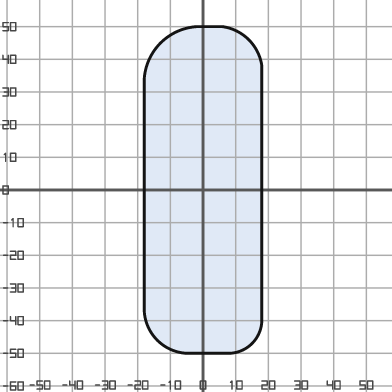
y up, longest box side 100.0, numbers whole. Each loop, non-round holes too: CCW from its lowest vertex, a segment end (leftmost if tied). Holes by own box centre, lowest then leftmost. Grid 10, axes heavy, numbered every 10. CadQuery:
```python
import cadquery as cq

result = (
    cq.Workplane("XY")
    .moveTo(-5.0, -50.0)
    .lineTo(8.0, -50.0)
    .threePointArc((15.0, -47.0), (18.0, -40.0))
    .lineTo(18.0, 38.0)
    .threePointArc((14.0, 46.0), (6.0, 50.0))
    .lineTo(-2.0, 50.0)
    .threePointArc((-13.0, 45.0), (-18.0, 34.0))
    .lineTo(-18.0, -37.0)
    .threePointArc((-14.0, -46.0), (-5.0, -50.0))
    .close()
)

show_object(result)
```